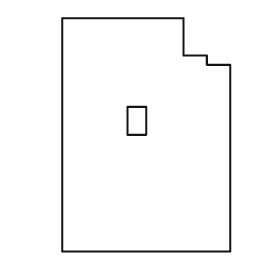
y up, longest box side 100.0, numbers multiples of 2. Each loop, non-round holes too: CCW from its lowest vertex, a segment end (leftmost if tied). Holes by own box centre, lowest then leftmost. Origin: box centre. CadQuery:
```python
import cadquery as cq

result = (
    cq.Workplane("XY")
    .moveTo(-36.0, -50.0)
    .lineTo(36.0, -50.0)
    .lineTo(36.0, 30.0)
    .lineTo(26.0, 30.0)
    .lineTo(26.0, 34.0)
    .lineTo(16.0, 34.0)
    .lineTo(16.0, 50.0)
    .lineTo(-36.0, 50.0)
    .close()
    .moveTo(-8.0, 0.0)
    .lineTo(0.0, 0.0)
    .lineTo(0.0, 12.0)
    .lineTo(-8.0, 12.0)
    .close()
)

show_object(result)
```